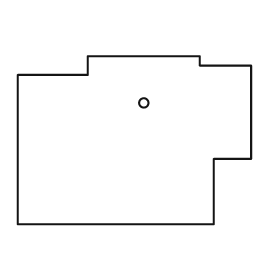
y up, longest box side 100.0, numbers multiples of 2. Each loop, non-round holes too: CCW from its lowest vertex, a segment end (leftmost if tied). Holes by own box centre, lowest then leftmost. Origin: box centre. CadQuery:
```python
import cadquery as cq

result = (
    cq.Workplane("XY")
    .moveTo(-50.0, -36.0)
    .lineTo(34.0, -36.0)
    .lineTo(34.0, -8.0)
    .lineTo(50.0, -8.0)
    .lineTo(50.0, 32.0)
    .lineTo(28.0, 32.0)
    .lineTo(28.0, 36.0)
    .lineTo(-20.0, 36.0)
    .lineTo(-20.0, 28.0)
    .lineTo(-50.0, 28.0)
    .close()
    .moveTo(4.0, 16.0)
    .circle(2.0)
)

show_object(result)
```